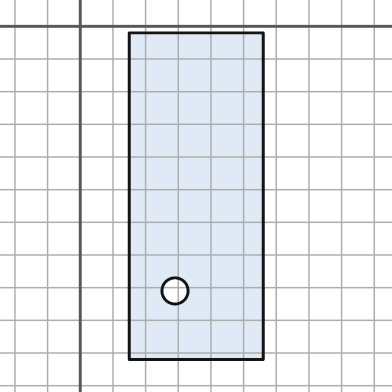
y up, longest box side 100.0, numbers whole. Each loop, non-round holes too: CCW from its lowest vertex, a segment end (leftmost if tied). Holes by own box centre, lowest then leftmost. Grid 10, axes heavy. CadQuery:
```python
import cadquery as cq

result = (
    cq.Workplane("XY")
    .moveTo(15.0, -102.0)
    .lineTo(56.0, -102.0)
    .lineTo(56.0, -2.0)
    .lineTo(15.0, -2.0)
    .close()
    .moveTo(29.0, -81.0)
    .circle(4.0)
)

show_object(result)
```